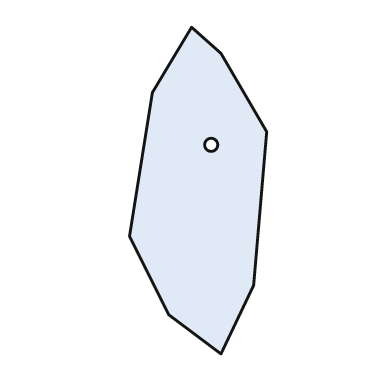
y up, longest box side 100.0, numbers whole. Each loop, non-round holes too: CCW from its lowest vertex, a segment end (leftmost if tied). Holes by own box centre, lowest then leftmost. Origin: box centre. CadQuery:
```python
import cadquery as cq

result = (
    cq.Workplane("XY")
    .moveTo(7.0, -50.0)
    .lineTo(17.0, -29.0)
    .lineTo(21.0, 18.0)
    .lineTo(7.0, 42.0)
    .lineTo(-2.0, 50.0)
    .lineTo(-14.0, 30.0)
    .lineTo(-21.0, -14.0)
    .lineTo(-9.0, -38.0)
    .close()
    .moveTo(4.0, 14.0)
    .circle(2.0)
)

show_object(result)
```